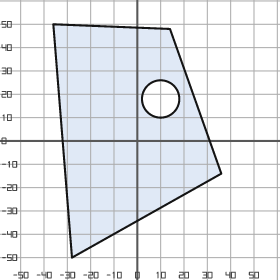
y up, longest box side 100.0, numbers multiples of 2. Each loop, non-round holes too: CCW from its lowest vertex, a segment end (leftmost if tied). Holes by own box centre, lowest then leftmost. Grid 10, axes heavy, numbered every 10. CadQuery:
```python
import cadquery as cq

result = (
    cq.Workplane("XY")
    .moveTo(-28.0, -50.0)
    .lineTo(36.0, -14.0)
    .lineTo(14.0, 48.0)
    .lineTo(-36.0, 50.0)
    .close()
    .moveTo(10.0, 18.0)
    .circle(8.0)
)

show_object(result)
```